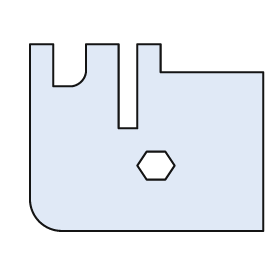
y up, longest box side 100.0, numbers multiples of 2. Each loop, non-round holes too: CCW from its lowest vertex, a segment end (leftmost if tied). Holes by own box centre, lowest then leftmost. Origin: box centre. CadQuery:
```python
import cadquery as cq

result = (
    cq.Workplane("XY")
    .moveTo(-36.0, -40.0)
    .lineTo(50.0, -40.0)
    .lineTo(50.0, 28.0)
    .lineTo(6.0, 28.0)
    .lineTo(6.0, 40.0)
    .lineTo(-4.0, 40.0)
    .lineTo(-4.0, 4.0)
    .lineTo(-12.0, 4.0)
    .lineTo(-12.0, 40.0)
    .lineTo(-26.0, 40.0)
    .lineTo(-26.0, 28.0)
    .threePointArc((-28.0, 24.0), (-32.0, 22.0))
    .lineTo(-40.0, 22.0)
    .lineTo(-40.0, 40.0)
    .lineTo(-50.0, 40.0)
    .lineTo(-50.0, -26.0)
    .threePointArc((-46.0, -36.0), (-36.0, -40.0))
    .close()
    .moveTo(0.0, -18.0)
    .lineTo(8.0, -18.0)
    .lineTo(12.0, -12.0)
    .lineTo(8.0, -6.0)
    .lineTo(0.0, -6.0)
    .lineTo(-4.0, -12.0)
    .close()
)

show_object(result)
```